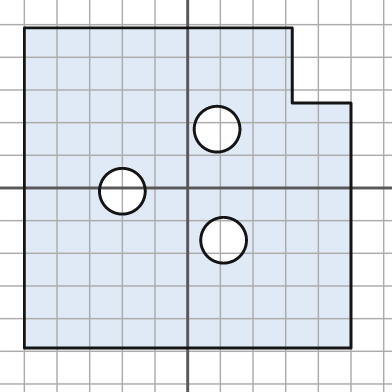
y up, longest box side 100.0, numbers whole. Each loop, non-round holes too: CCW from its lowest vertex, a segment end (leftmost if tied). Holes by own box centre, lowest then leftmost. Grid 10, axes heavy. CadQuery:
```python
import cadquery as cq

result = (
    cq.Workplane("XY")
    .moveTo(-50.0, -49.0)
    .lineTo(50.0, -49.0)
    .lineTo(50.0, 26.0)
    .lineTo(32.0, 26.0)
    .lineTo(32.0, 49.0)
    .lineTo(-50.0, 49.0)
    .close()
    .moveTo(11.0, -16.0)
    .circle(7.0)
    .moveTo(-20.0, -1.0)
    .circle(7.0)
    .moveTo(9.0, 18.0)
    .circle(7.0)
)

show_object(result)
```